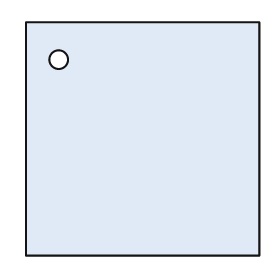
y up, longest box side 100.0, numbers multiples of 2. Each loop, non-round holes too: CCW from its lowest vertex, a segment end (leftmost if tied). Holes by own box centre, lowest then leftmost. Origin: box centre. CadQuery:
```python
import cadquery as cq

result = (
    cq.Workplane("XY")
    .moveTo(-50.0, -50.0)
    .lineTo(50.0, -50.0)
    .lineTo(50.0, 50.0)
    .lineTo(-50.0, 50.0)
    .close()
    .moveTo(-36.0, 34.0)
    .circle(4.0)
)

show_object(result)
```